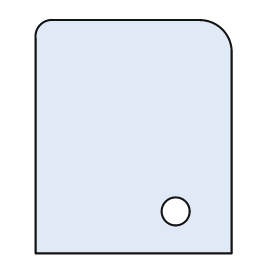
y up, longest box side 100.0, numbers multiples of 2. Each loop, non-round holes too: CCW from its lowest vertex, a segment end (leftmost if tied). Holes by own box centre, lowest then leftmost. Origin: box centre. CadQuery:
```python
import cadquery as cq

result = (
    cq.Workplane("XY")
    .moveTo(-42.0, -50.0)
    .lineTo(42.0, -50.0)
    .lineTo(42.0, 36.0)
    .threePointArc((38.0, 46.0), (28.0, 50.0))
    .lineTo(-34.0, 50.0)
    .threePointArc((-40.0, 48.0), (-42.0, 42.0))
    .close()
    .moveTo(18.0, -32.0)
    .circle(6.0)
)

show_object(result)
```